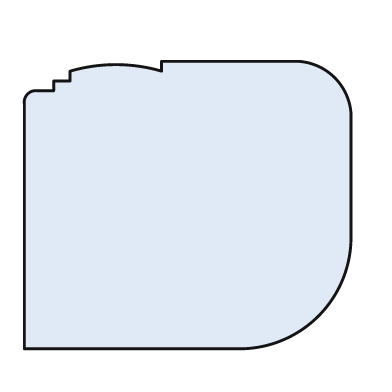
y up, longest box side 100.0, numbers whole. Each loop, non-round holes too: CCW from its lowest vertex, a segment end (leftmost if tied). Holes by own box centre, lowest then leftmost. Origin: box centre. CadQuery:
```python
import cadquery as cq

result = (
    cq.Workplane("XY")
    .moveTo(-50.0, -44.0)
    .lineTo(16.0, -44.0)
    .threePointArc((40.0, -34.0), (50.0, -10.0))
    .lineTo(50.0, 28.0)
    .threePointArc((45.0, 39.0), (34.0, 44.0))
    .lineTo(-8.0, 44.0)
    .lineTo(-8.0, 41.0)
    .threePointArc((-22.0, 43.0), (-36.0, 41.0))
    .lineTo(-36.0, 38.0)
    .lineTo(-41.0, 38.0)
    .lineTo(-41.0, 35.0)
    .lineTo(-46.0, 35.0)
    .threePointArc((-49.0, 34.0), (-50.0, 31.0))
    .close()
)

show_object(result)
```